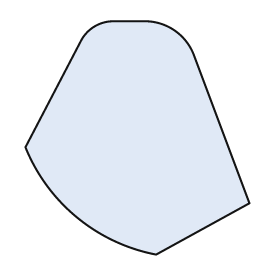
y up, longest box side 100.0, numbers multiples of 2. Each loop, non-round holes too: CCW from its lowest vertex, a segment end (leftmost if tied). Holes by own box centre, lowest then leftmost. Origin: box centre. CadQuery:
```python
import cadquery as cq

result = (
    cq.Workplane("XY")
    .moveTo(8.0, -50.0)
    .lineTo(48.0, -28.0)
    .lineTo(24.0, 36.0)
    .threePointArc((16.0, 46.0), (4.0, 50.0))
    .lineTo(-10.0, 50.0)
    .threePointArc((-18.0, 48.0), (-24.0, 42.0))
    .lineTo(-48.0, -4.0)
    .threePointArc((-26.0, -34.0), (8.0, -50.0))
    .close()
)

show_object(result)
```